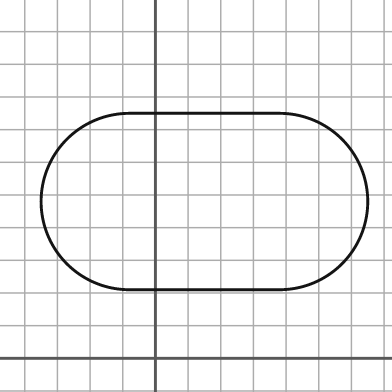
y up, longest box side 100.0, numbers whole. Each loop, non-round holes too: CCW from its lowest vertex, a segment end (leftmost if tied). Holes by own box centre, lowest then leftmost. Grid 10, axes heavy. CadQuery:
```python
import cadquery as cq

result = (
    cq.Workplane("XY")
    .moveTo(-8.0, 21.0)
    .lineTo(38.0, 21.0)
    .threePointArc((65.0, 48.0), (38.0, 75.0))
    .lineTo(-8.0, 75.0)
    .threePointArc((-35.0, 48.0), (-8.0, 21.0))
    .close()
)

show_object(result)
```